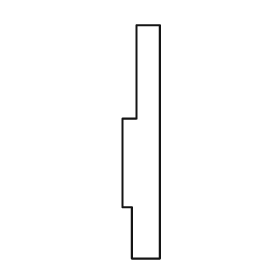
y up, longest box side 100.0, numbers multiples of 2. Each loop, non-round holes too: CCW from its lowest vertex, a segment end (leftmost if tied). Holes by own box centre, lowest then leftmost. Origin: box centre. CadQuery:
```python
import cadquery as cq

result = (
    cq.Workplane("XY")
    .moveTo(-4.0, -50.0)
    .lineTo(8.0, -50.0)
    .lineTo(8.0, 50.0)
    .lineTo(-2.0, 50.0)
    .lineTo(-2.0, 10.0)
    .lineTo(-8.0, 10.0)
    .lineTo(-8.0, -28.0)
    .lineTo(-4.0, -28.0)
    .close()
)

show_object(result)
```